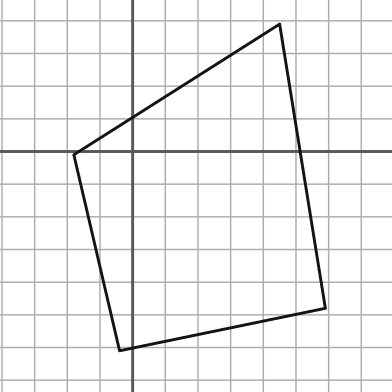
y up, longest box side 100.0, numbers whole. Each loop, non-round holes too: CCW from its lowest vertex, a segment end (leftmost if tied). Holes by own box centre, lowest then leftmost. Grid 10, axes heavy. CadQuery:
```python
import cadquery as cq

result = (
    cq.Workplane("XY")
    .moveTo(-4.0, -61.0)
    .lineTo(59.0, -48.0)
    .lineTo(45.0, 39.0)
    .lineTo(-18.0, -1.0)
    .close()
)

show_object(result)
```